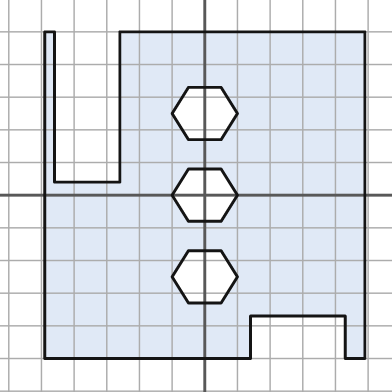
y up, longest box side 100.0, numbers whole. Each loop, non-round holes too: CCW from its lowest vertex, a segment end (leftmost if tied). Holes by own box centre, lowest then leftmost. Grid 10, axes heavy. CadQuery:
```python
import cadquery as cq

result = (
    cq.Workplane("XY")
    .moveTo(-49.0, -50.0)
    .lineTo(14.0, -50.0)
    .lineTo(14.0, -37.0)
    .lineTo(43.0, -37.0)
    .lineTo(43.0, -50.0)
    .lineTo(49.0, -50.0)
    .lineTo(49.0, 50.0)
    .lineTo(-26.0, 50.0)
    .lineTo(-26.0, 4.0)
    .lineTo(-46.0, 4.0)
    .lineTo(-46.0, 50.0)
    .lineTo(-49.0, 50.0)
    .close()
    .moveTo(-5.0, -33.0)
    .lineTo(5.0, -33.0)
    .lineTo(10.0, -25.0)
    .lineTo(5.0, -17.0)
    .lineTo(-5.0, -17.0)
    .lineTo(-10.0, -25.0)
    .close()
    .moveTo(-5.0, -8.0)
    .lineTo(5.0, -8.0)
    .lineTo(10.0, 0.0)
    .lineTo(5.0, 8.0)
    .lineTo(-5.0, 8.0)
    .lineTo(-10.0, 0.0)
    .close()
    .moveTo(-5.0, 17.0)
    .lineTo(5.0, 17.0)
    .lineTo(10.0, 25.0)
    .lineTo(5.0, 33.0)
    .lineTo(-5.0, 33.0)
    .lineTo(-10.0, 25.0)
    .close()
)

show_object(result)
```